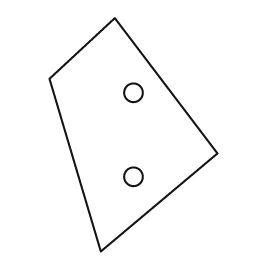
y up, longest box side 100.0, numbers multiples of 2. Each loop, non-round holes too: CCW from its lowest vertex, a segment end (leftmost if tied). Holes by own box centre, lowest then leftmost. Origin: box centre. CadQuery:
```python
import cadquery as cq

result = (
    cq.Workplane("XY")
    .moveTo(-14.0, -50.0)
    .lineTo(36.0, -8.0)
    .lineTo(-8.0, 50.0)
    .lineTo(-36.0, 24.0)
    .close()
    .moveTo(0.0, -18.0)
    .circle(4.0)
    .moveTo(0.0, 18.0)
    .circle(4.0)
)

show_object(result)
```